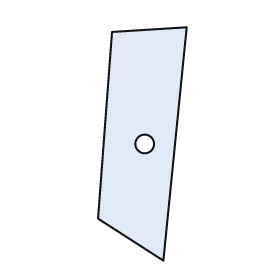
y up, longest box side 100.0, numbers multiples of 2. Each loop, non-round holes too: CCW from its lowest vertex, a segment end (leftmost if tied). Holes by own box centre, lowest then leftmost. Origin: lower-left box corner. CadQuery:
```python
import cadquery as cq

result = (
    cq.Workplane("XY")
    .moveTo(28.0, 0.0)
    .lineTo(38.0, 100.0)
    .lineTo(6.0, 98.0)
    .lineTo(0.0, 18.0)
    .close()
    .moveTo(20.0, 50.0)
    .circle(4.0)
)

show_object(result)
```